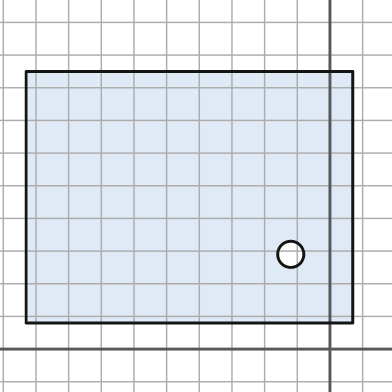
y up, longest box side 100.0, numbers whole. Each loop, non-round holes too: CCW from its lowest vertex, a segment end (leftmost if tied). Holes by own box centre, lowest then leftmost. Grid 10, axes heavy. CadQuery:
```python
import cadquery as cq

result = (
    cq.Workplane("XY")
    .moveTo(-93.0, 8.0)
    .lineTo(7.0, 8.0)
    .lineTo(7.0, 85.0)
    .lineTo(-93.0, 85.0)
    .close()
    .moveTo(-12.0, 29.0)
    .circle(4.0)
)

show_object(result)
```